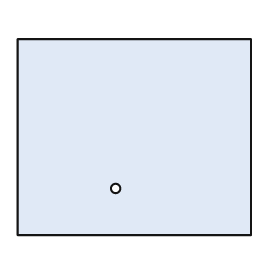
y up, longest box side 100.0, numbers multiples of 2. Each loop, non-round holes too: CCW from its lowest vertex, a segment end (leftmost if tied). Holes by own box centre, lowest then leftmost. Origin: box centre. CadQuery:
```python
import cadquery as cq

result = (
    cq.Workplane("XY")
    .moveTo(-50.0, -42.0)
    .lineTo(50.0, -42.0)
    .lineTo(50.0, 42.0)
    .lineTo(-50.0, 42.0)
    .close()
    .moveTo(-8.0, -22.0)
    .circle(2.0)
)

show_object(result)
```